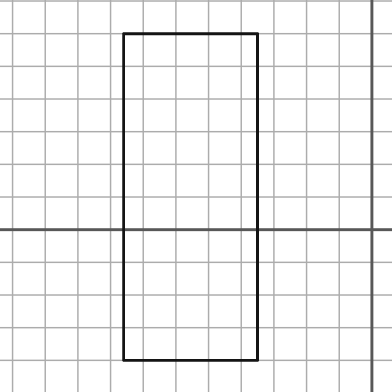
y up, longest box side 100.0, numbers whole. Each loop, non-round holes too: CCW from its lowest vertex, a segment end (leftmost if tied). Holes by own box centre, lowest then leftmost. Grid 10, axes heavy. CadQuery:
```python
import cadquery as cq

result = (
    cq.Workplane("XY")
    .moveTo(-76.0, -40.0)
    .lineTo(-35.0, -40.0)
    .lineTo(-35.0, 60.0)
    .lineTo(-76.0, 60.0)
    .close()
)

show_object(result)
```